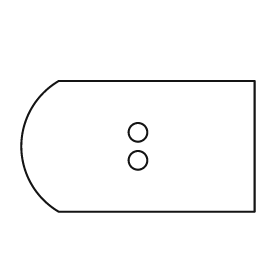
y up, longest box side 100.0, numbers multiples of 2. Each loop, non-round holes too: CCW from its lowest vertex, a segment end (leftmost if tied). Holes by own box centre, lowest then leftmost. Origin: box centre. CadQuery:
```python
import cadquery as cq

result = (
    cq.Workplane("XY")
    .moveTo(-34.0, -28.0)
    .lineTo(50.0, -28.0)
    .lineTo(50.0, 28.0)
    .lineTo(-34.0, 28.0)
    .threePointArc((-50.0, 0.0), (-34.0, -28.0))
    .close()
    .moveTo(0.0, -6.0)
    .circle(4.0)
    .moveTo(0.0, 6.0)
    .circle(4.0)
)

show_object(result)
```